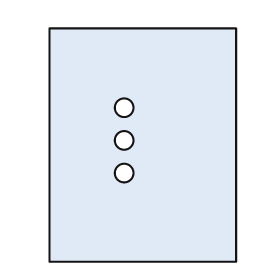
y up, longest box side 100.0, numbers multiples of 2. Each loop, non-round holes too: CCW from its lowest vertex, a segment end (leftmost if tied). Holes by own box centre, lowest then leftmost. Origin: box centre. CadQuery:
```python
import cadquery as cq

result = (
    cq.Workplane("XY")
    .moveTo(-40.0, -50.0)
    .lineTo(40.0, -50.0)
    .lineTo(40.0, 50.0)
    .lineTo(-40.0, 50.0)
    .close()
    .moveTo(-8.0, -12.0)
    .circle(4.0)
    .moveTo(-8.0, 2.0)
    .circle(4.0)
    .moveTo(-8.0, 16.0)
    .circle(4.0)
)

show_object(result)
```